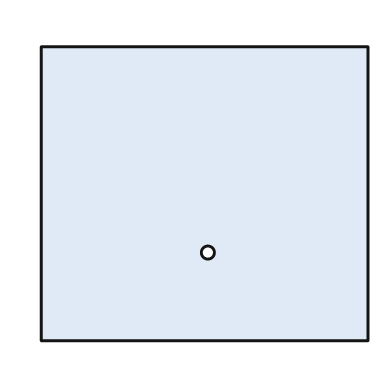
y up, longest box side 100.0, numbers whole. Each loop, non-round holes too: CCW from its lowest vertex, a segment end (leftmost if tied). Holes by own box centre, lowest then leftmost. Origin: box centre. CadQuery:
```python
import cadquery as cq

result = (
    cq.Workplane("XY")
    .moveTo(-50.0, -45.0)
    .lineTo(50.0, -45.0)
    .lineTo(50.0, 45.0)
    .lineTo(-50.0, 45.0)
    .close()
    .moveTo(1.0, -18.0)
    .circle(2.0)
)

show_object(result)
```